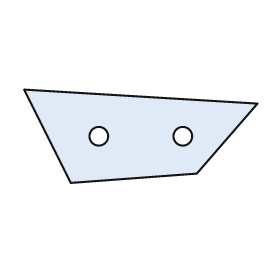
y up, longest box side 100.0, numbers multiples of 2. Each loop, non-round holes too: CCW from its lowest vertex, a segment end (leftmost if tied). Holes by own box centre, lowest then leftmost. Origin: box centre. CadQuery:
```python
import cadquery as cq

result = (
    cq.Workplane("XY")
    .moveTo(-30.0, -20.0)
    .lineTo(24.0, -16.0)
    .lineTo(50.0, 14.0)
    .lineTo(-50.0, 20.0)
    .close()
    .moveTo(-18.0, 0.0)
    .circle(4.0)
    .moveTo(18.0, 0.0)
    .circle(4.0)
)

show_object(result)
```